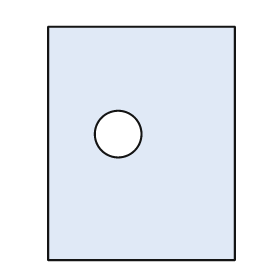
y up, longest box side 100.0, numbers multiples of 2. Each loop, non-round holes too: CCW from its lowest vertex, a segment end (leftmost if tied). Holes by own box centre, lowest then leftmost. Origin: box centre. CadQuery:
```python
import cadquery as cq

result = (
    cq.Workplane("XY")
    .moveTo(-40.0, -50.0)
    .lineTo(40.0, -50.0)
    .lineTo(40.0, 50.0)
    .lineTo(-40.0, 50.0)
    .close()
    .moveTo(-10.0, 4.0)
    .circle(10.0)
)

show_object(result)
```